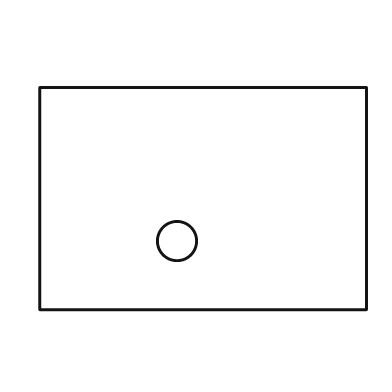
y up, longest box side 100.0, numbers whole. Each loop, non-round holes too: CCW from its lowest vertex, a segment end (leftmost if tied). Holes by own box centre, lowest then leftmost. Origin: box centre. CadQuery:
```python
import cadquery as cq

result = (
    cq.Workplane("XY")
    .moveTo(-50.0, -34.0)
    .lineTo(50.0, -34.0)
    .lineTo(50.0, 34.0)
    .lineTo(-50.0, 34.0)
    .close()
    .moveTo(-8.0, -13.0)
    .circle(6.0)
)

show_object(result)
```